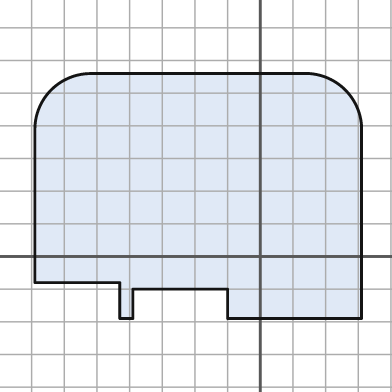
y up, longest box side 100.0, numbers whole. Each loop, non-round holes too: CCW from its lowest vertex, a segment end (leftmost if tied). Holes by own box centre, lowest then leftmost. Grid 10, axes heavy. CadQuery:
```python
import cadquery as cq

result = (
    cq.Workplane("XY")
    .moveTo(-43.0, -19.0)
    .lineTo(-39.0, -19.0)
    .lineTo(-39.0, -10.0)
    .lineTo(-10.0, -10.0)
    .lineTo(-10.0, -19.0)
    .lineTo(31.0, -19.0)
    .lineTo(31.0, 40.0)
    .threePointArc((26.0, 51.0), (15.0, 56.0))
    .lineTo(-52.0, 56.0)
    .threePointArc((-64.0, 51.0), (-69.0, 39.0))
    .lineTo(-69.0, -8.0)
    .lineTo(-43.0, -8.0)
    .close()
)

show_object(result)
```